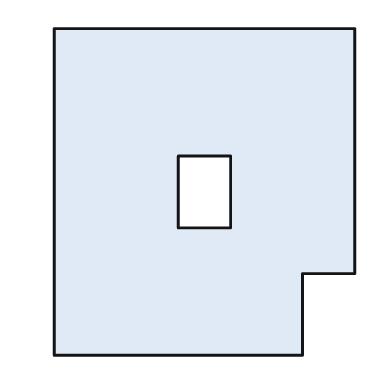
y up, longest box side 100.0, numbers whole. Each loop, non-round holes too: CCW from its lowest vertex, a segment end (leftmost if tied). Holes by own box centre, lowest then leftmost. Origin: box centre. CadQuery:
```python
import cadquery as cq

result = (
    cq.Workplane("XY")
    .moveTo(-46.0, -50.0)
    .lineTo(30.0, -50.0)
    .lineTo(30.0, -25.0)
    .lineTo(46.0, -25.0)
    .lineTo(46.0, 50.0)
    .lineTo(-46.0, 50.0)
    .close()
    .moveTo(-8.0, -11.0)
    .lineTo(8.0, -11.0)
    .lineTo(8.0, 11.0)
    .lineTo(-8.0, 11.0)
    .close()
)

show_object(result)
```